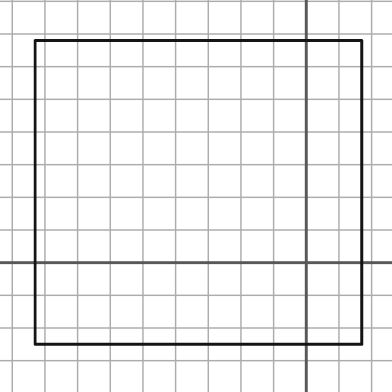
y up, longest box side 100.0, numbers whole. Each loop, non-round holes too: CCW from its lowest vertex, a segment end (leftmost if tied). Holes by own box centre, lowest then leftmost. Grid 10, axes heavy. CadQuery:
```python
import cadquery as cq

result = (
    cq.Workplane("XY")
    .moveTo(-83.0, -25.0)
    .lineTo(17.0, -25.0)
    .lineTo(17.0, 68.0)
    .lineTo(-83.0, 68.0)
    .close()
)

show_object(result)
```